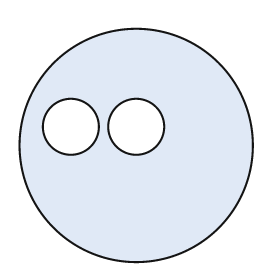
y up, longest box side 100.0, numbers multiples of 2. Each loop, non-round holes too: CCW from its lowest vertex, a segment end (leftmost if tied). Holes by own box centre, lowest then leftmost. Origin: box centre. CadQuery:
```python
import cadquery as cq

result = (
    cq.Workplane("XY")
    .moveTo(0.0, 0.0)
    .circle(50.0)
    .moveTo(-28.0, 8.0)
    .circle(12.0)
    .moveTo(0.0, 8.0)
    .circle(12.0)
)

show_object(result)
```